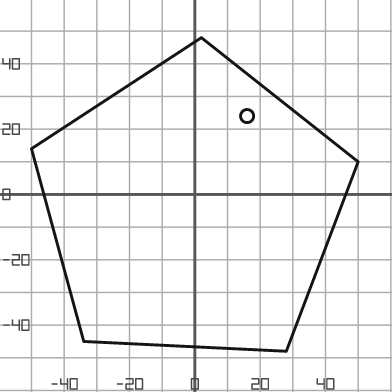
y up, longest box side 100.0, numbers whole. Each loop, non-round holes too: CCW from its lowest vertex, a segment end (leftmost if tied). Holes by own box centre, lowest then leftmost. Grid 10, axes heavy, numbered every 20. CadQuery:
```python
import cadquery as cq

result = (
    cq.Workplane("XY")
    .moveTo(28.0, -48.0)
    .lineTo(50.0, 10.0)
    .lineTo(2.0, 48.0)
    .lineTo(-50.0, 14.0)
    .lineTo(-34.0, -45.0)
    .close()
    .moveTo(16.0, 24.0)
    .circle(2.0)
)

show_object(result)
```